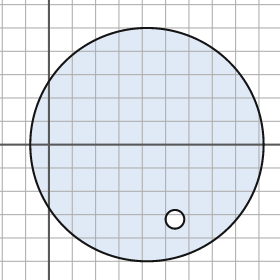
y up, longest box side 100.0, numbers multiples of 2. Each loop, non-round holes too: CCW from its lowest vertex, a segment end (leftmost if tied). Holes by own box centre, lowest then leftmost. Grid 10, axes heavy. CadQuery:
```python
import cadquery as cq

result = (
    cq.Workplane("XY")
    .moveTo(42.0, 0.0)
    .circle(50.0)
    .moveTo(54.0, -32.0)
    .circle(4.0)
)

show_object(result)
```